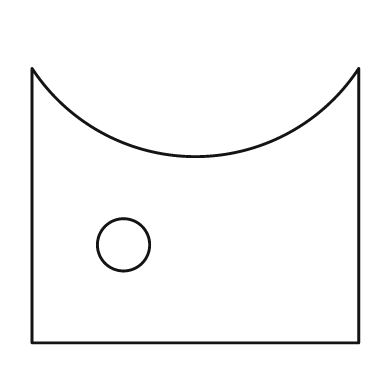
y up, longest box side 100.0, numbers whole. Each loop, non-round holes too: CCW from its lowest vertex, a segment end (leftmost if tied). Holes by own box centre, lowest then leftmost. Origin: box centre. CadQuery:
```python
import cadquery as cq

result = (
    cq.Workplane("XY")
    .moveTo(-50.0, -42.0)
    .lineTo(50.0, -42.0)
    .lineTo(50.0, 42.0)
    .threePointArc((0.0, 15.0), (-50.0, 42.0))
    .close()
    .moveTo(-22.0, -12.0)
    .circle(8.0)
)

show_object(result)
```